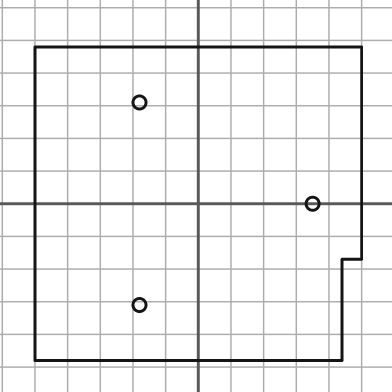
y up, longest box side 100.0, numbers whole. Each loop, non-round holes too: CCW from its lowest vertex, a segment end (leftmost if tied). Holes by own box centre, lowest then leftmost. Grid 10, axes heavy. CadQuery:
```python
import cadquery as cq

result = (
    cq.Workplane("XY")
    .moveTo(-50.0, -48.0)
    .lineTo(44.0, -48.0)
    .lineTo(44.0, -17.0)
    .lineTo(50.0, -17.0)
    .lineTo(50.0, 48.0)
    .lineTo(-50.0, 48.0)
    .close()
    .moveTo(-18.0, -31.0)
    .circle(2.0)
    .moveTo(35.0, 0.0)
    .circle(2.0)
    .moveTo(-18.0, 31.0)
    .circle(2.0)
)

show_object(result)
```